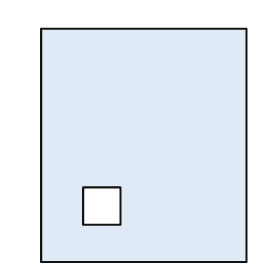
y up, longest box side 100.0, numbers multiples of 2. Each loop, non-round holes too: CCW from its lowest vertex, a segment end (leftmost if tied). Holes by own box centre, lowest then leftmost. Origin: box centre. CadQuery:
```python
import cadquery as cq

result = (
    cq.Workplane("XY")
    .moveTo(-44.0, -50.0)
    .lineTo(44.0, -50.0)
    .lineTo(44.0, 50.0)
    .lineTo(-44.0, 50.0)
    .close()
    .moveTo(-26.0, -34.0)
    .lineTo(-10.0, -34.0)
    .lineTo(-10.0, -18.0)
    .lineTo(-26.0, -18.0)
    .close()
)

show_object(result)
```